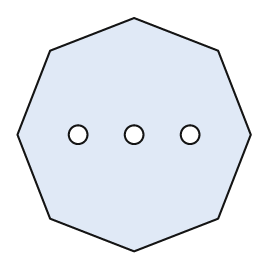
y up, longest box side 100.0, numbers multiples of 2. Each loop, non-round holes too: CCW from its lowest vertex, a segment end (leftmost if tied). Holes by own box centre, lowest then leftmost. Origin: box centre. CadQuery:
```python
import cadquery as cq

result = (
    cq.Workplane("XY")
    .moveTo(0.0, -50.0)
    .lineTo(36.0, -36.0)
    .lineTo(50.0, 0.0)
    .lineTo(36.0, 36.0)
    .lineTo(0.0, 50.0)
    .lineTo(-36.0, 36.0)
    .lineTo(-50.0, 0.0)
    .lineTo(-36.0, -36.0)
    .close()
    .moveTo(-24.0, 0.0)
    .circle(4.0)
    .moveTo(0.0, 0.0)
    .circle(4.0)
    .moveTo(24.0, 0.0)
    .circle(4.0)
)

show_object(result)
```